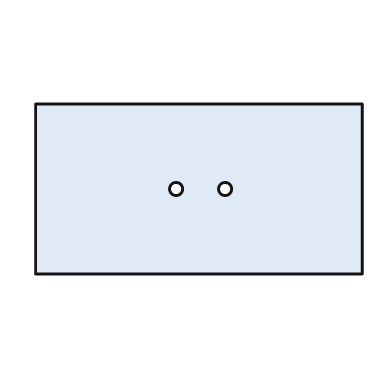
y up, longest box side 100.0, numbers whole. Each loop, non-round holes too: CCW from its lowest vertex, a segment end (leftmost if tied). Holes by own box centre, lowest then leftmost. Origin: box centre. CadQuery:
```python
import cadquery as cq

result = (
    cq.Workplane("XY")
    .moveTo(-50.0, -26.0)
    .lineTo(50.0, -26.0)
    .lineTo(50.0, 26.0)
    .lineTo(-50.0, 26.0)
    .close()
    .moveTo(-7.0, 0.0)
    .circle(2.0)
    .moveTo(8.0, 0.0)
    .circle(2.0)
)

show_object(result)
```